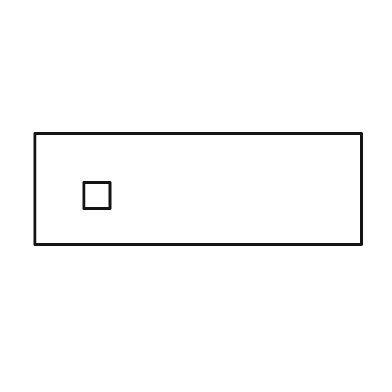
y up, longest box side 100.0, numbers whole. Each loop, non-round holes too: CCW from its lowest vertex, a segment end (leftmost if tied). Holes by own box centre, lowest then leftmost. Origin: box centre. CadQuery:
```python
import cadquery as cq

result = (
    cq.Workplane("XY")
    .moveTo(-50.0, -17.0)
    .lineTo(50.0, -17.0)
    .lineTo(50.0, 17.0)
    .lineTo(-50.0, 17.0)
    .close()
    .moveTo(-35.0, -6.0)
    .lineTo(-27.0, -6.0)
    .lineTo(-27.0, 2.0)
    .lineTo(-35.0, 2.0)
    .close()
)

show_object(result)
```